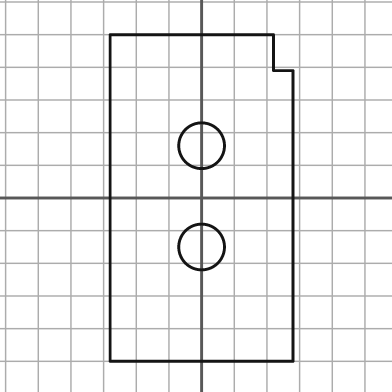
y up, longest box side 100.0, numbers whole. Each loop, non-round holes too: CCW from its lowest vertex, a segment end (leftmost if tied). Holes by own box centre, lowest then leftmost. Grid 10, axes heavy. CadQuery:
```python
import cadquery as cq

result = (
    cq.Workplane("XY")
    .moveTo(-28.0, -50.0)
    .lineTo(28.0, -50.0)
    .lineTo(28.0, 39.0)
    .lineTo(22.0, 39.0)
    .lineTo(22.0, 50.0)
    .lineTo(-28.0, 50.0)
    .close()
    .moveTo(0.0, -15.0)
    .circle(7.0)
    .moveTo(0.0, 16.0)
    .circle(7.0)
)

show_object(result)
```